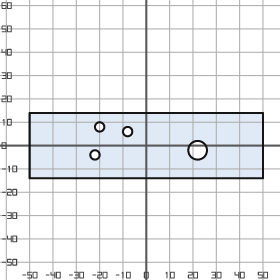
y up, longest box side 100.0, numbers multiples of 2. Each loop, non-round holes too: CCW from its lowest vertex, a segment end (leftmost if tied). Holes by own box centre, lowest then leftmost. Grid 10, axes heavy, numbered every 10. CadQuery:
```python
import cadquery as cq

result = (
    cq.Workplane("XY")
    .moveTo(-50.0, -14.0)
    .lineTo(50.0, -14.0)
    .lineTo(50.0, 14.0)
    .lineTo(-50.0, 14.0)
    .close()
    .moveTo(-22.0, -4.0)
    .circle(2.0)
    .moveTo(22.0, -2.0)
    .circle(4.0)
    .moveTo(-8.0, 6.0)
    .circle(2.0)
    .moveTo(-20.0, 8.0)
    .circle(2.0)
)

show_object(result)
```